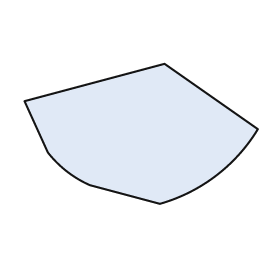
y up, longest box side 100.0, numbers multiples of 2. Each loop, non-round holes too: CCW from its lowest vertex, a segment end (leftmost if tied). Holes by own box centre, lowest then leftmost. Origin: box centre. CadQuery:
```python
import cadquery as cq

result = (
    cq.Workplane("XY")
    .moveTo(8.0, -30.0)
    .threePointArc((32.0, -18.0), (50.0, 2.0))
    .lineTo(10.0, 30.0)
    .lineTo(-50.0, 14.0)
    .lineTo(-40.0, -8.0)
    .threePointArc((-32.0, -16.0), (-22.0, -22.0))
    .close()
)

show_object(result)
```